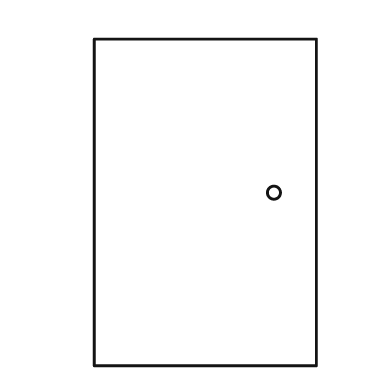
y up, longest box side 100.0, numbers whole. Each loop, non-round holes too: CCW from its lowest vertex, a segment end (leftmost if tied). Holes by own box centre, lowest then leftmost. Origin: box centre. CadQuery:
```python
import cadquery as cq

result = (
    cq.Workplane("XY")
    .moveTo(-34.0, -50.0)
    .lineTo(34.0, -50.0)
    .lineTo(34.0, 50.0)
    .lineTo(-34.0, 50.0)
    .close()
    .moveTo(21.0, 3.0)
    .circle(2.0)
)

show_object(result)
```